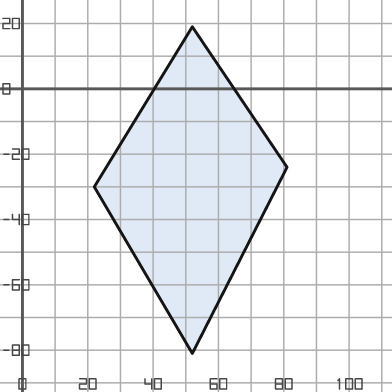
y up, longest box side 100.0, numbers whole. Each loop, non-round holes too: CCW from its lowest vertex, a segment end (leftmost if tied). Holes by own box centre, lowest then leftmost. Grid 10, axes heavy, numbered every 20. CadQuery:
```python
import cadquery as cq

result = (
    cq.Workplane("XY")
    .moveTo(52.0, -81.0)
    .lineTo(81.0, -24.0)
    .lineTo(52.0, 19.0)
    .lineTo(22.0, -30.0)
    .close()
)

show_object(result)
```